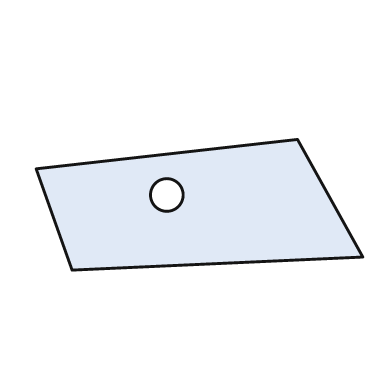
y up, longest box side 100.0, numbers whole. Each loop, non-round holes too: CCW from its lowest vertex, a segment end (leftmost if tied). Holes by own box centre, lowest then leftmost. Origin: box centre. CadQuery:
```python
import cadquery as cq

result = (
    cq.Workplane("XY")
    .moveTo(-39.0, -20.0)
    .lineTo(50.0, -16.0)
    .lineTo(30.0, 20.0)
    .lineTo(-50.0, 11.0)
    .close()
    .moveTo(-10.0, 3.0)
    .circle(5.0)
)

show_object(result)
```